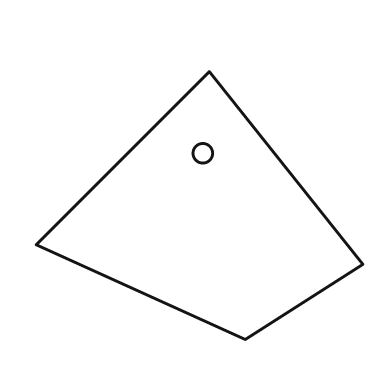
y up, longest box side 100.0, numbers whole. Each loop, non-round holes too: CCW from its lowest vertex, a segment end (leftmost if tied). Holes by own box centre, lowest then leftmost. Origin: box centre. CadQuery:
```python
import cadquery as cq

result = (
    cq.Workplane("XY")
    .moveTo(14.0, -41.0)
    .lineTo(50.0, -18.0)
    .lineTo(3.0, 41.0)
    .lineTo(-50.0, -12.0)
    .close()
    .moveTo(1.0, 16.0)
    .circle(3.0)
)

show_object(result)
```